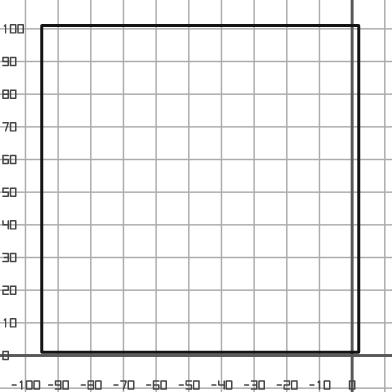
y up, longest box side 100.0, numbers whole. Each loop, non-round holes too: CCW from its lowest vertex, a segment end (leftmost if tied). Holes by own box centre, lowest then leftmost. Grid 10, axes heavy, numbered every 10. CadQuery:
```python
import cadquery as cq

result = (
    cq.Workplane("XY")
    .moveTo(-95.0, 1.0)
    .lineTo(2.0, 1.0)
    .lineTo(2.0, 101.0)
    .lineTo(-95.0, 101.0)
    .close()
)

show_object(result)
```